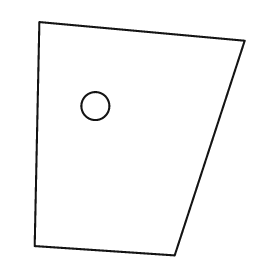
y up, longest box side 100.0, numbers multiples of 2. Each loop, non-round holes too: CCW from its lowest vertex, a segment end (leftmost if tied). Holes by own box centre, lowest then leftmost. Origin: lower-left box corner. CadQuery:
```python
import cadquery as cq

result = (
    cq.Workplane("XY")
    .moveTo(60.0, 0.0)
    .lineTo(90.0, 92.0)
    .lineTo(2.0, 100.0)
    .lineTo(0.0, 4.0)
    .close()
    .moveTo(26.0, 64.0)
    .circle(6.0)
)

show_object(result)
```